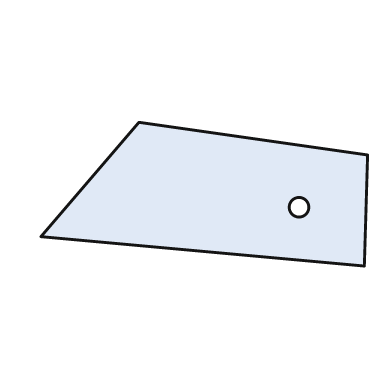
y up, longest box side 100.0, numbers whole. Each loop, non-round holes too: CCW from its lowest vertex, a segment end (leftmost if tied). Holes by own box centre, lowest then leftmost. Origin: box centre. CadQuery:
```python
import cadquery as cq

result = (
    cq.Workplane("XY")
    .moveTo(49.0, -22.0)
    .lineTo(50.0, 12.0)
    .lineTo(-20.0, 22.0)
    .lineTo(-50.0, -13.0)
    .close()
    .moveTo(29.0, -4.0)
    .circle(3.0)
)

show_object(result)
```